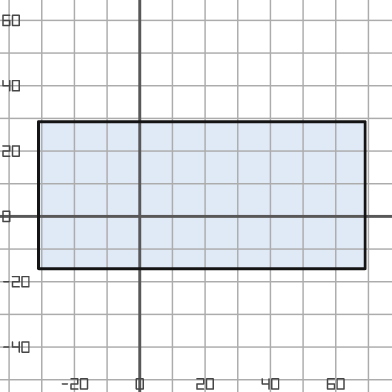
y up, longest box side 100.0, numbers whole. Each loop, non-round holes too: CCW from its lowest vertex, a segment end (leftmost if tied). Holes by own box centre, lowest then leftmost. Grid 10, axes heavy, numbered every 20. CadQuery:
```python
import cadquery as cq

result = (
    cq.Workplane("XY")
    .moveTo(-31.0, -16.0)
    .lineTo(69.0, -16.0)
    .lineTo(69.0, 29.0)
    .lineTo(-31.0, 29.0)
    .close()
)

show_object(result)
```